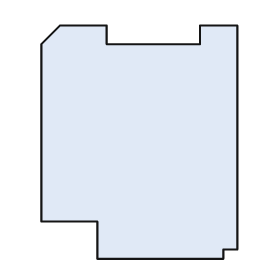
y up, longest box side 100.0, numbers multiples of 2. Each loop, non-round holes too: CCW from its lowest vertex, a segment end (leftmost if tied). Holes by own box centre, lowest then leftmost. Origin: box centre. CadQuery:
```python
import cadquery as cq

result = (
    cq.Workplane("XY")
    .moveTo(-18.0, -50.0)
    .lineTo(36.0, -50.0)
    .lineTo(36.0, -46.0)
    .lineTo(42.0, -46.0)
    .lineTo(42.0, 50.0)
    .lineTo(26.0, 50.0)
    .lineTo(26.0, 42.0)
    .lineTo(-14.0, 42.0)
    .lineTo(-14.0, 50.0)
    .lineTo(-34.0, 50.0)
    .lineTo(-42.0, 42.0)
    .lineTo(-42.0, -34.0)
    .lineTo(-18.0, -34.0)
    .close()
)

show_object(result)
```